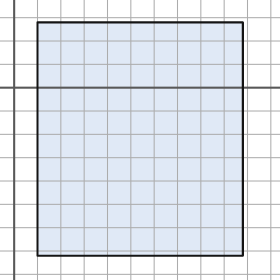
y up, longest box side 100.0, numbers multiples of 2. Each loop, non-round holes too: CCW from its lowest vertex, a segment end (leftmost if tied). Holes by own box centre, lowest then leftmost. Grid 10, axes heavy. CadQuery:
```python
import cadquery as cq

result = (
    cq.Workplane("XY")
    .moveTo(10.0, -72.0)
    .lineTo(98.0, -72.0)
    .lineTo(98.0, 28.0)
    .lineTo(10.0, 28.0)
    .close()
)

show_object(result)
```